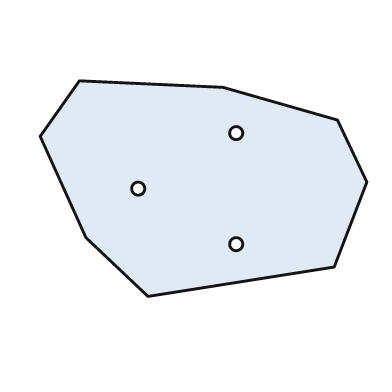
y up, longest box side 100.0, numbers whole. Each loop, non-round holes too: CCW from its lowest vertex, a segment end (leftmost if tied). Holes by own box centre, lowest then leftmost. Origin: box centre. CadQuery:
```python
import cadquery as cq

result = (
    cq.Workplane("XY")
    .moveTo(-17.0, -33.0)
    .lineTo(40.0, -24.0)
    .lineTo(50.0, 2.0)
    .lineTo(41.0, 21.0)
    .lineTo(6.0, 31.0)
    .lineTo(-38.0, 33.0)
    .lineTo(-50.0, 16.0)
    .lineTo(-36.0, -15.0)
    .close()
    .moveTo(10.0, -17.0)
    .circle(2.0)
    .moveTo(-20.0, 0.0)
    .circle(2.0)
    .moveTo(10.0, 17.0)
    .circle(2.0)
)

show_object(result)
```